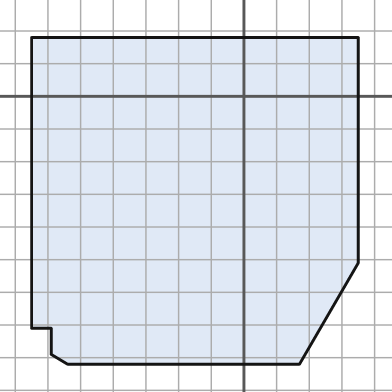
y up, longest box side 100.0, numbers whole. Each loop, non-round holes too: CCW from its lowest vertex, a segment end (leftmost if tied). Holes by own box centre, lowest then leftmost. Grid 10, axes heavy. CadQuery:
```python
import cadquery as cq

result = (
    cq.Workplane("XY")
    .moveTo(-54.0, -82.0)
    .lineTo(17.0, -82.0)
    .lineTo(35.0, -51.0)
    .lineTo(35.0, 18.0)
    .lineTo(-65.0, 18.0)
    .lineTo(-65.0, -71.0)
    .lineTo(-59.0, -71.0)
    .lineTo(-59.0, -79.0)
    .close()
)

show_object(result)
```